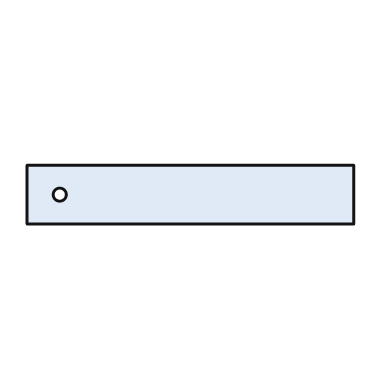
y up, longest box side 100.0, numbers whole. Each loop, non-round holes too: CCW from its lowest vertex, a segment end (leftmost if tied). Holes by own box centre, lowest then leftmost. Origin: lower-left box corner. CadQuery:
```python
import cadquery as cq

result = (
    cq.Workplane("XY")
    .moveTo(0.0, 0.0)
    .lineTo(100.0, 0.0)
    .lineTo(100.0, 18.0)
    .lineTo(0.0, 18.0)
    .close()
    .moveTo(10.0, 9.0)
    .circle(2.0)
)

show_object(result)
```